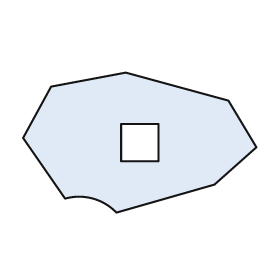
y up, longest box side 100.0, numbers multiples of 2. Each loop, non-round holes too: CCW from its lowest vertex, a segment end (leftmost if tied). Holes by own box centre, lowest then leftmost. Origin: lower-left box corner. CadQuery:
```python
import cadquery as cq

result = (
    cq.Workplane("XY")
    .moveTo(40.0, 0.0)
    .lineTo(82.0, 12.0)
    .lineTo(100.0, 28.0)
    .lineTo(88.0, 48.0)
    .lineTo(44.0, 60.0)
    .lineTo(12.0, 54.0)
    .lineTo(0.0, 32.0)
    .lineTo(18.0, 6.0)
    .threePointArc((30.0, 6.0), (40.0, 0.0))
    .close()
    .moveTo(42.0, 22.0)
    .lineTo(58.0, 22.0)
    .lineTo(58.0, 38.0)
    .lineTo(42.0, 38.0)
    .close()
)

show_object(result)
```